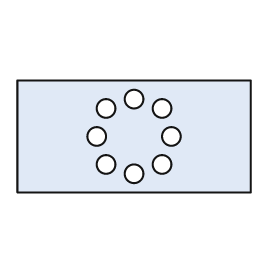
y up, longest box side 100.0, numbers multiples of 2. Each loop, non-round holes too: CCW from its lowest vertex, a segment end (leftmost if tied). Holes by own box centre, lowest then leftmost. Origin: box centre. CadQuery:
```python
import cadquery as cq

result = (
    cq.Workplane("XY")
    .moveTo(-50.0, -24.0)
    .lineTo(50.0, -24.0)
    .lineTo(50.0, 24.0)
    .lineTo(-50.0, 24.0)
    .close()
    .moveTo(0.0, -16.0)
    .circle(4.0)
    .moveTo(-12.0, -12.0)
    .circle(4.0)
    .moveTo(12.0, -12.0)
    .circle(4.0)
    .moveTo(-16.0, 0.0)
    .circle(4.0)
    .moveTo(16.0, 0.0)
    .circle(4.0)
    .moveTo(-12.0, 12.0)
    .circle(4.0)
    .moveTo(12.0, 12.0)
    .circle(4.0)
    .moveTo(0.0, 16.0)
    .circle(4.0)
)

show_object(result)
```